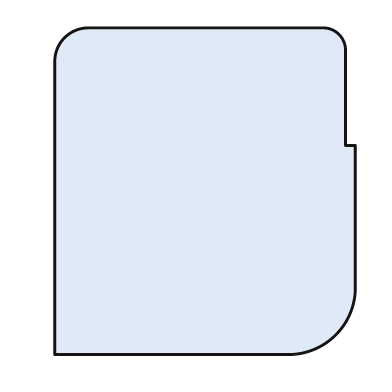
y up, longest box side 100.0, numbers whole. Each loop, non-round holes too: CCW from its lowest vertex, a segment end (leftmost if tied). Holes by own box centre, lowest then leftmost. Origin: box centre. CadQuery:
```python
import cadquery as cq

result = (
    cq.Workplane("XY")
    .moveTo(-46.0, -50.0)
    .lineTo(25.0, -50.0)
    .threePointArc((40.0, -44.0), (46.0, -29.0))
    .lineTo(46.0, 14.0)
    .lineTo(43.0, 14.0)
    .lineTo(43.0, 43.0)
    .threePointArc((41.0, 48.0), (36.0, 50.0))
    .lineTo(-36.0, 50.0)
    .threePointArc((-43.0, 47.0), (-46.0, 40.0))
    .close()
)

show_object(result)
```